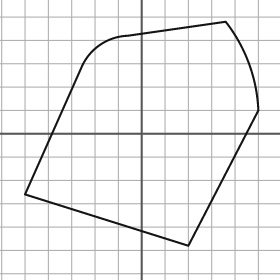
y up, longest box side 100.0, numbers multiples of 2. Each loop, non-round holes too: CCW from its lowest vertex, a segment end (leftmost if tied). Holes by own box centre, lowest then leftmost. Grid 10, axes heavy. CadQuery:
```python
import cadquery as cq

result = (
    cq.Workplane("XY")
    .moveTo(20.0, -48.0)
    .lineTo(50.0, 10.0)
    .threePointArc((46.0, 30.0), (36.0, 48.0))
    .lineTo(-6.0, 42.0)
    .threePointArc((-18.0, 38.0), (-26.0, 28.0))
    .lineTo(-50.0, -26.0)
    .close()
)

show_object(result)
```